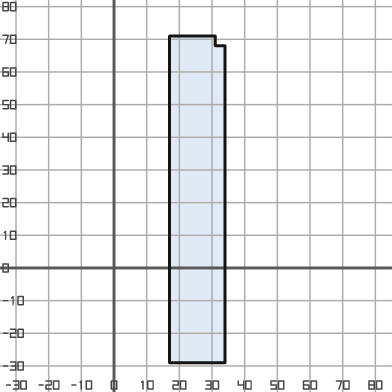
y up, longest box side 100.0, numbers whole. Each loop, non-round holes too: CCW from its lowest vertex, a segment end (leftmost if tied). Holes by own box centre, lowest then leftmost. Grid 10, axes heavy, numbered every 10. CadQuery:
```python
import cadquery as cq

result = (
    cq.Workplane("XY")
    .moveTo(17.0, -29.0)
    .lineTo(34.0, -29.0)
    .lineTo(34.0, 68.0)
    .lineTo(31.0, 68.0)
    .lineTo(31.0, 71.0)
    .lineTo(17.0, 71.0)
    .close()
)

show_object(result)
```